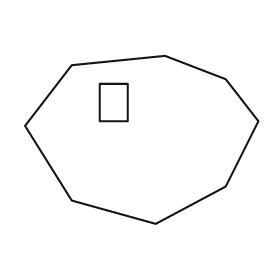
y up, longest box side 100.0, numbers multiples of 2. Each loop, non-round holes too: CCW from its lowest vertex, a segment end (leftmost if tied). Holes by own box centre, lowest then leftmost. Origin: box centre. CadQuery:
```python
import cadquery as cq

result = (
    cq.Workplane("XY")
    .moveTo(6.0, -36.0)
    .lineTo(36.0, -20.0)
    .lineTo(50.0, 8.0)
    .lineTo(36.0, 26.0)
    .lineTo(10.0, 36.0)
    .lineTo(-30.0, 32.0)
    .lineTo(-50.0, 6.0)
    .lineTo(-30.0, -26.0)
    .close()
    .moveTo(-18.0, 8.0)
    .lineTo(-6.0, 8.0)
    .lineTo(-6.0, 24.0)
    .lineTo(-18.0, 24.0)
    .close()
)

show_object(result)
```